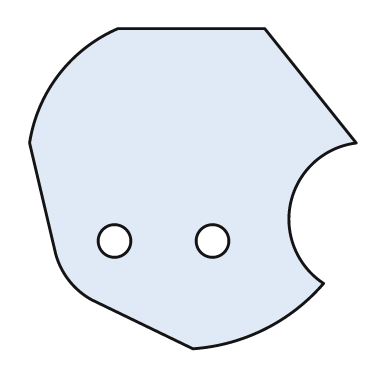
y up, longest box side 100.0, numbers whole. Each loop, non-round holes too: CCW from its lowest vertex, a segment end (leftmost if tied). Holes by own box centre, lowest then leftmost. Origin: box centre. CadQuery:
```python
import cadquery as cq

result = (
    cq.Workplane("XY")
    .moveTo(0.0, -49.0)
    .threePointArc((22.0, -43.0), (40.0, -29.0))
    .threePointArc((30.0, -4.0), (50.0, 14.0))
    .lineTo(22.0, 49.0)
    .lineTo(-23.0, 49.0)
    .threePointArc((-41.0, 35.0), (-50.0, 14.0))
    .lineTo(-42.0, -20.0)
    .threePointArc((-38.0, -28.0), (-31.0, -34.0))
    .close()
    .moveTo(-24.0, -16.0)
    .circle(5.0)
    .moveTo(6.0, -16.0)
    .circle(5.0)
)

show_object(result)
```